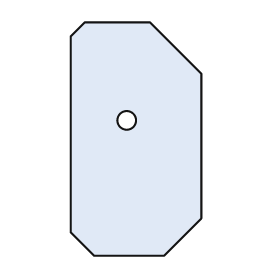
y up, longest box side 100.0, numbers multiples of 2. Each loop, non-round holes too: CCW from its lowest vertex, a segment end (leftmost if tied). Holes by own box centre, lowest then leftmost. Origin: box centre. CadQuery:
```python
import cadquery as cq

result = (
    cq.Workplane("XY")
    .moveTo(-18.0, -50.0)
    .lineTo(12.0, -50.0)
    .lineTo(28.0, -34.0)
    .lineTo(28.0, 28.0)
    .lineTo(6.0, 50.0)
    .lineTo(-22.0, 50.0)
    .lineTo(-28.0, 44.0)
    .lineTo(-28.0, -40.0)
    .close()
    .moveTo(-4.0, 8.0)
    .circle(4.0)
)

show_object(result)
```